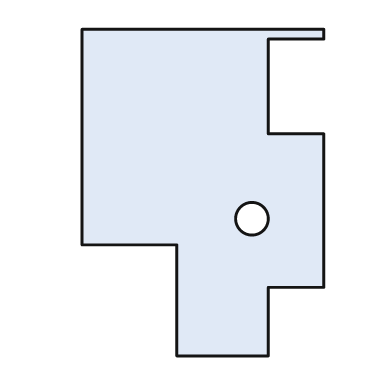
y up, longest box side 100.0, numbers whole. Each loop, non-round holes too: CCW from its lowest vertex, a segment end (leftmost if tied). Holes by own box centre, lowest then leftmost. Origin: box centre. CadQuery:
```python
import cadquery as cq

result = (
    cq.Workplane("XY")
    .moveTo(-8.0, -50.0)
    .lineTo(20.0, -50.0)
    .lineTo(20.0, -29.0)
    .lineTo(37.0, -29.0)
    .lineTo(37.0, 18.0)
    .lineTo(20.0, 18.0)
    .lineTo(20.0, 47.0)
    .lineTo(37.0, 47.0)
    .lineTo(37.0, 50.0)
    .lineTo(-37.0, 50.0)
    .lineTo(-37.0, -16.0)
    .lineTo(-8.0, -16.0)
    .close()
    .moveTo(15.0, -8.0)
    .circle(5.0)
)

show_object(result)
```